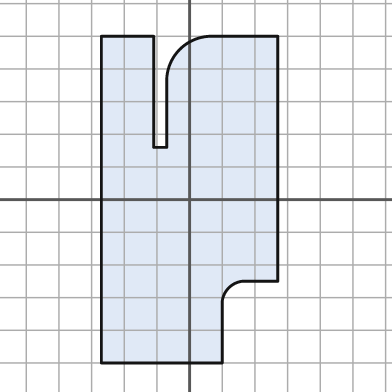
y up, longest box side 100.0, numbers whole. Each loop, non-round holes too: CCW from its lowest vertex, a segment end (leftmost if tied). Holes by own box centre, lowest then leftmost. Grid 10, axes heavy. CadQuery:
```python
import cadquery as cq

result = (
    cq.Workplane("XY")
    .moveTo(-27.0, -50.0)
    .lineTo(10.0, -50.0)
    .lineTo(10.0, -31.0)
    .threePointArc((12.0, -27.0), (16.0, -25.0))
    .lineTo(27.0, -25.0)
    .lineTo(27.0, 50.0)
    .lineTo(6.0, 50.0)
    .threePointArc((-3.0, 46.0), (-7.0, 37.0))
    .lineTo(-7.0, 16.0)
    .lineTo(-11.0, 16.0)
    .lineTo(-11.0, 50.0)
    .lineTo(-27.0, 50.0)
    .close()
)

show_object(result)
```